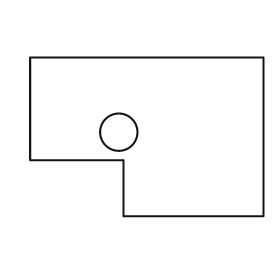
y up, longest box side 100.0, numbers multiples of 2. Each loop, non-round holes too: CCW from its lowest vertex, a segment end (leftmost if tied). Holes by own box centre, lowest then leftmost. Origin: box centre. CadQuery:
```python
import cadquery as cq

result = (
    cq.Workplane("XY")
    .moveTo(-10.0, -34.0)
    .lineTo(50.0, -34.0)
    .lineTo(50.0, 34.0)
    .lineTo(-50.0, 34.0)
    .lineTo(-50.0, -10.0)
    .lineTo(-10.0, -10.0)
    .close()
    .moveTo(-12.0, 2.0)
    .circle(8.0)
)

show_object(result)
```